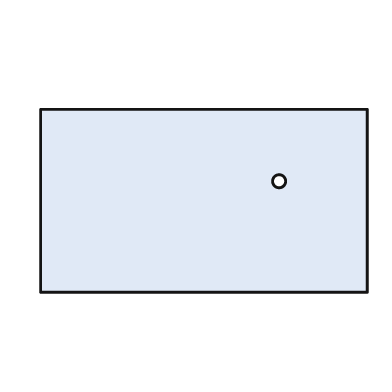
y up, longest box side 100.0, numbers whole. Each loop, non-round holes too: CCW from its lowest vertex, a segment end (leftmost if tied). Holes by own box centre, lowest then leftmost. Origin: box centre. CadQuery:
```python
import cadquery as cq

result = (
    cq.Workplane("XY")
    .moveTo(-50.0, -28.0)
    .lineTo(50.0, -28.0)
    .lineTo(50.0, 28.0)
    .lineTo(-50.0, 28.0)
    .close()
    .moveTo(23.0, 6.0)
    .circle(2.0)
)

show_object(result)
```